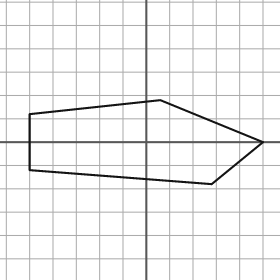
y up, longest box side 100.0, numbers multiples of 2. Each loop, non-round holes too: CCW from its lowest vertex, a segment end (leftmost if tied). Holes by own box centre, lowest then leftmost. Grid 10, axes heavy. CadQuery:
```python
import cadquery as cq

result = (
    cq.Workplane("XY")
    .moveTo(28.0, -18.0)
    .lineTo(50.0, 0.0)
    .lineTo(6.0, 18.0)
    .lineTo(-50.0, 12.0)
    .lineTo(-50.0, -12.0)
    .close()
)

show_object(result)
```